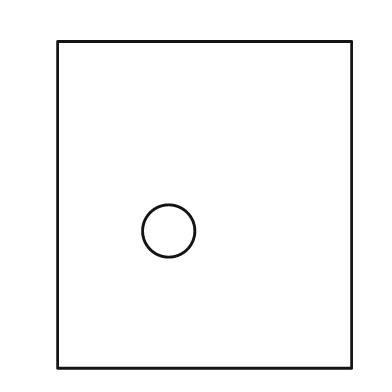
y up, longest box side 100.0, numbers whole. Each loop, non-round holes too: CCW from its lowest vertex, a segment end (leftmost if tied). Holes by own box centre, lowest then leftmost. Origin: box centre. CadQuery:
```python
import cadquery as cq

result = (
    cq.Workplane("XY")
    .moveTo(-45.0, -50.0)
    .lineTo(45.0, -50.0)
    .lineTo(45.0, 50.0)
    .lineTo(-45.0, 50.0)
    .close()
    .moveTo(-11.0, -8.0)
    .circle(8.0)
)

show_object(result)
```